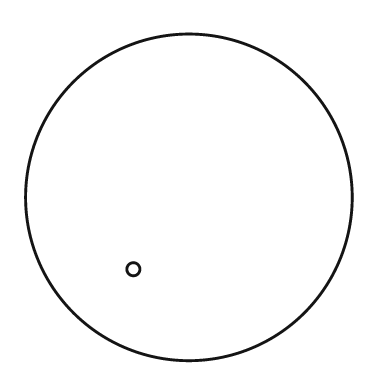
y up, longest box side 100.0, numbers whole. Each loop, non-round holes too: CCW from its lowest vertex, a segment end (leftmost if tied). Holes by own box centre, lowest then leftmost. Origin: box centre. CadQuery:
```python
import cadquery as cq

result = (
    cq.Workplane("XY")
    .moveTo(0.0, 0.0)
    .circle(50.0)
    .moveTo(-17.0, -22.0)
    .circle(2.0)
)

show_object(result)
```